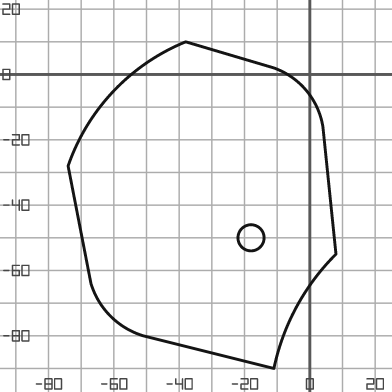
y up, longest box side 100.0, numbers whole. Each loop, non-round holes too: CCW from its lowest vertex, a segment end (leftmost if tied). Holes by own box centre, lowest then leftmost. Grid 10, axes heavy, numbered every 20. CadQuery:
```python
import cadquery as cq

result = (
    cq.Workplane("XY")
    .moveTo(-11.0, -90.0)
    .threePointArc((-4.0, -71.0), (8.0, -55.0))
    .lineTo(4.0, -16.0)
    .threePointArc((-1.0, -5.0), (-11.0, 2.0))
    .lineTo(-38.0, 10.0)
    .threePointArc((-60.0, -5.0), (-74.0, -28.0))
    .lineTo(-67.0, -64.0)
    .threePointArc((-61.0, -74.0), (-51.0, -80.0))
    .close()
    .moveTo(-18.0, -50.0)
    .circle(4.0)
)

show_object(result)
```